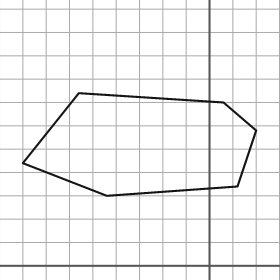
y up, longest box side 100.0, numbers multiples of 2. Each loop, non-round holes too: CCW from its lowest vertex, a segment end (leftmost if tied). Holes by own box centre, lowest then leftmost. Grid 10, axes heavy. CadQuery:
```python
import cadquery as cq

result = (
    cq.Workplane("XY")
    .moveTo(-44.0, 30.0)
    .lineTo(12.0, 34.0)
    .lineTo(20.0, 58.0)
    .lineTo(6.0, 70.0)
    .lineTo(-56.0, 74.0)
    .lineTo(-80.0, 44.0)
    .close()
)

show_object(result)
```